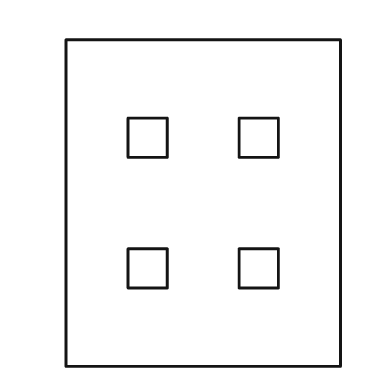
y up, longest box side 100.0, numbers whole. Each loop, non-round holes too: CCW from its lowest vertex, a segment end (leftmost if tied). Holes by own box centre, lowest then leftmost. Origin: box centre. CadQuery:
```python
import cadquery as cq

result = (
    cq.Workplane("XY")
    .moveTo(-42.0, -50.0)
    .lineTo(42.0, -50.0)
    .lineTo(42.0, 50.0)
    .lineTo(-42.0, 50.0)
    .close()
    .moveTo(-23.0, -26.0)
    .lineTo(-11.0, -26.0)
    .lineTo(-11.0, -14.0)
    .lineTo(-23.0, -14.0)
    .close()
    .moveTo(11.0, -26.0)
    .lineTo(23.0, -26.0)
    .lineTo(23.0, -14.0)
    .lineTo(11.0, -14.0)
    .close()
    .moveTo(-23.0, 14.0)
    .lineTo(-11.0, 14.0)
    .lineTo(-11.0, 26.0)
    .lineTo(-23.0, 26.0)
    .close()
    .moveTo(11.0, 14.0)
    .lineTo(23.0, 14.0)
    .lineTo(23.0, 26.0)
    .lineTo(11.0, 26.0)
    .close()
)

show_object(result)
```